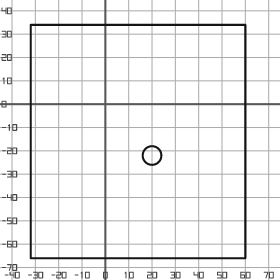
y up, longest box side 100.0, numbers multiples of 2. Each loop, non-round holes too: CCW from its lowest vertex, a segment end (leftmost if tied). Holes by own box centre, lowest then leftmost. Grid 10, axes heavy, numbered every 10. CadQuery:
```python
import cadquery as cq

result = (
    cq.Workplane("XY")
    .moveTo(-32.0, -66.0)
    .lineTo(60.0, -66.0)
    .lineTo(60.0, 34.0)
    .lineTo(-32.0, 34.0)
    .close()
    .moveTo(20.0, -22.0)
    .circle(4.0)
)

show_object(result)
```